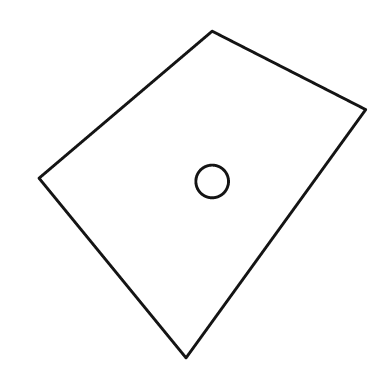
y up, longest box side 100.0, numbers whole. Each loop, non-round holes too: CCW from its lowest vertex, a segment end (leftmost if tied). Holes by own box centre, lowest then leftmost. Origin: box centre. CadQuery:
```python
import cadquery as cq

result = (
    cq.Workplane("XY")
    .moveTo(-5.0, -50.0)
    .lineTo(50.0, 26.0)
    .lineTo(3.0, 50.0)
    .lineTo(-50.0, 5.0)
    .close()
    .moveTo(3.0, 4.0)
    .circle(5.0)
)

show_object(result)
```